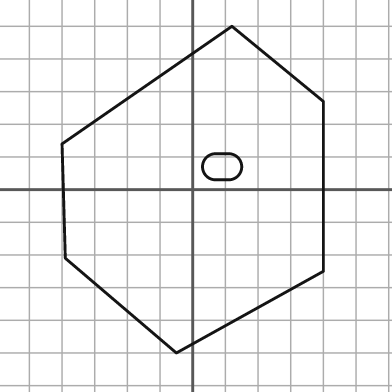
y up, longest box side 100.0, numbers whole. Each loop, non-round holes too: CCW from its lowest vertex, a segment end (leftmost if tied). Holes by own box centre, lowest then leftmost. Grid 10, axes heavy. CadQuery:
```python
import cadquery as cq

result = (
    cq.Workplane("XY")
    .moveTo(-5.0, -50.0)
    .lineTo(40.0, -25.0)
    .lineTo(40.0, 27.0)
    .lineTo(12.0, 50.0)
    .lineTo(-40.0, 14.0)
    .lineTo(-39.0, -21.0)
    .close()
    .moveTo(7.0, 3.0)
    .lineTo(11.0, 3.0)
    .threePointArc((15.0, 7.0), (11.0, 11.0))
    .lineTo(7.0, 11.0)
    .threePointArc((3.0, 7.0), (7.0, 3.0))
    .close()
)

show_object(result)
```